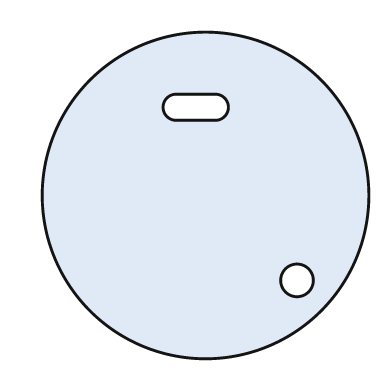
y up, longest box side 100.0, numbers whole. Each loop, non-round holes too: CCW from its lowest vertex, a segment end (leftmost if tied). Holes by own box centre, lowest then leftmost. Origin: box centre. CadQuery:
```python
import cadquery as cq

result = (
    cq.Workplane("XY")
    .moveTo(0.0, 0.0)
    .circle(50.0)
    .moveTo(28.0, -26.0)
    .circle(5.0)
    .moveTo(-9.0, 23.0)
    .lineTo(3.0, 23.0)
    .threePointArc((7.0, 27.0), (3.0, 31.0))
    .lineTo(-9.0, 31.0)
    .threePointArc((-13.0, 27.0), (-9.0, 23.0))
    .close()
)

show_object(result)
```